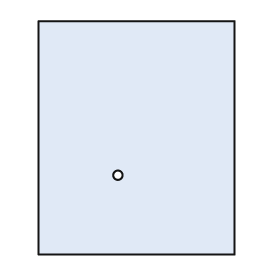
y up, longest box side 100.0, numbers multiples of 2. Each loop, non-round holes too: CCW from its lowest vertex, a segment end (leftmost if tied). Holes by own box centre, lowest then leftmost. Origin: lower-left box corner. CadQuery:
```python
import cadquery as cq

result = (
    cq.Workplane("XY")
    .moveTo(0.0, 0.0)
    .lineTo(84.0, 0.0)
    .lineTo(84.0, 100.0)
    .lineTo(0.0, 100.0)
    .close()
    .moveTo(34.0, 34.0)
    .circle(2.0)
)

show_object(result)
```